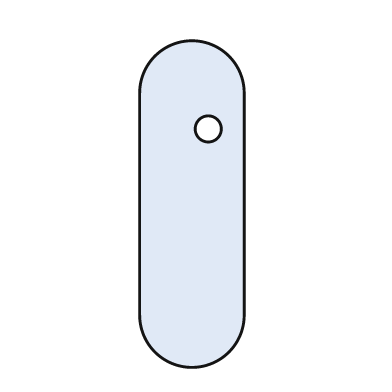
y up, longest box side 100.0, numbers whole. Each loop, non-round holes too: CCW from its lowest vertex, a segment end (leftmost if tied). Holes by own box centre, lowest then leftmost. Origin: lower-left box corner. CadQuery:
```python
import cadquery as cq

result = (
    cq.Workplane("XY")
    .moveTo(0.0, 16.0)
    .threePointArc((16.0, 0.0), (32.0, 16.0))
    .lineTo(32.0, 84.0)
    .threePointArc((16.0, 100.0), (0.0, 84.0))
    .close()
    .moveTo(21.0, 73.0)
    .circle(4.0)
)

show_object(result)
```